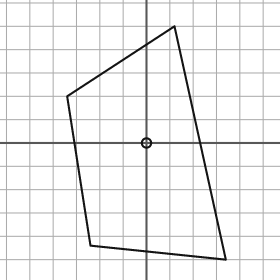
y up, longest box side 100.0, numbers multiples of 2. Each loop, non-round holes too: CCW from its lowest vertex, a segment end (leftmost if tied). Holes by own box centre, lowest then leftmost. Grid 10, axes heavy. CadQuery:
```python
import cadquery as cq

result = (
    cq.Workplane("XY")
    .moveTo(34.0, -50.0)
    .lineTo(12.0, 50.0)
    .lineTo(-34.0, 20.0)
    .lineTo(-24.0, -44.0)
    .close()
    .moveTo(0.0, 0.0)
    .circle(2.0)
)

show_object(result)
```